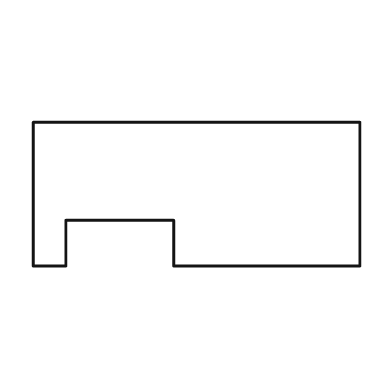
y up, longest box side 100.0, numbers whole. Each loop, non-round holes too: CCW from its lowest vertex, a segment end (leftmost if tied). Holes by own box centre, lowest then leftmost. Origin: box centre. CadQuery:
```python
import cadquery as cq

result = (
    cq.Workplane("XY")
    .moveTo(-50.0, -22.0)
    .lineTo(-40.0, -22.0)
    .lineTo(-40.0, -8.0)
    .lineTo(-7.0, -8.0)
    .lineTo(-7.0, -22.0)
    .lineTo(50.0, -22.0)
    .lineTo(50.0, 22.0)
    .lineTo(-50.0, 22.0)
    .close()
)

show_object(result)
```